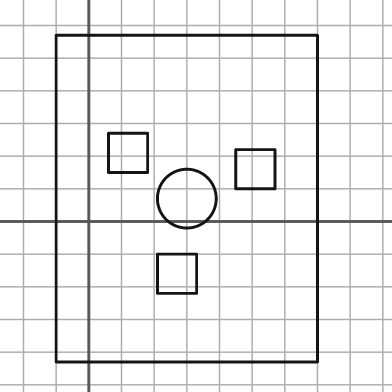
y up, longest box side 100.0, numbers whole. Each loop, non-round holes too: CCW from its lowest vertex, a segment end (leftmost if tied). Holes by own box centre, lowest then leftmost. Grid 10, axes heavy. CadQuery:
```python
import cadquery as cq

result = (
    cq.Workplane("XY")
    .moveTo(-10.0, -43.0)
    .lineTo(70.0, -43.0)
    .lineTo(70.0, 57.0)
    .lineTo(-10.0, 57.0)
    .close()
    .moveTo(21.0, -22.0)
    .lineTo(33.0, -22.0)
    .lineTo(33.0, -10.0)
    .lineTo(21.0, -10.0)
    .close()
    .moveTo(30.0, 7.0)
    .circle(9.0)
    .moveTo(45.0, 10.0)
    .lineTo(57.0, 10.0)
    .lineTo(57.0, 22.0)
    .lineTo(45.0, 22.0)
    .close()
    .moveTo(6.0, 15.0)
    .lineTo(18.0, 15.0)
    .lineTo(18.0, 27.0)
    .lineTo(6.0, 27.0)
    .close()
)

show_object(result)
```